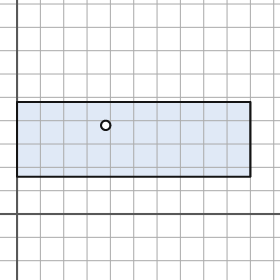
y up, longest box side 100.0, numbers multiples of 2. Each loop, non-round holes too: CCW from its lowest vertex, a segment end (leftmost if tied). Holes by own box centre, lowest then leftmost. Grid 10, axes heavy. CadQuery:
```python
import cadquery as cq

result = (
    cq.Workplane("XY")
    .moveTo(0.0, 16.0)
    .lineTo(100.0, 16.0)
    .lineTo(100.0, 48.0)
    .lineTo(0.0, 48.0)
    .close()
    .moveTo(38.0, 38.0)
    .circle(2.0)
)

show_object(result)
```